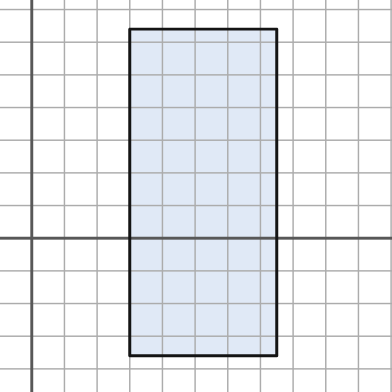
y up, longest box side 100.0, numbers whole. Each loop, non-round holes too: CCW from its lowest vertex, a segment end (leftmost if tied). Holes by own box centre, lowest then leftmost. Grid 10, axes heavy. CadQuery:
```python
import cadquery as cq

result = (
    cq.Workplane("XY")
    .moveTo(30.0, -36.0)
    .lineTo(75.0, -36.0)
    .lineTo(75.0, 64.0)
    .lineTo(30.0, 64.0)
    .close()
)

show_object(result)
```